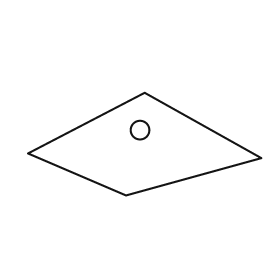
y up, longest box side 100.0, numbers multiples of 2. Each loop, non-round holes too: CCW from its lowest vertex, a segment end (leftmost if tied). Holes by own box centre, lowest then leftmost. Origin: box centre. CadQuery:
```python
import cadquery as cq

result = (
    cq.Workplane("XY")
    .moveTo(-8.0, -22.0)
    .lineTo(50.0, -6.0)
    .lineTo(0.0, 22.0)
    .lineTo(-50.0, -4.0)
    .close()
    .moveTo(-2.0, 6.0)
    .circle(4.0)
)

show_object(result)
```